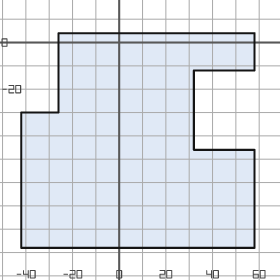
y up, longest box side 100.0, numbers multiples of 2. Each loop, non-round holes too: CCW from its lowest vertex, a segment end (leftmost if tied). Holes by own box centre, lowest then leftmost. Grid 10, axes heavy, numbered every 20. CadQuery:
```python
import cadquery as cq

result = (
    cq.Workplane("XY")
    .moveTo(-42.0, -88.0)
    .lineTo(58.0, -88.0)
    .lineTo(58.0, -46.0)
    .lineTo(32.0, -46.0)
    .lineTo(32.0, -12.0)
    .lineTo(58.0, -12.0)
    .lineTo(58.0, 4.0)
    .lineTo(-26.0, 4.0)
    .lineTo(-26.0, -30.0)
    .lineTo(-42.0, -30.0)
    .close()
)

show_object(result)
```